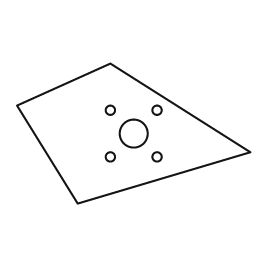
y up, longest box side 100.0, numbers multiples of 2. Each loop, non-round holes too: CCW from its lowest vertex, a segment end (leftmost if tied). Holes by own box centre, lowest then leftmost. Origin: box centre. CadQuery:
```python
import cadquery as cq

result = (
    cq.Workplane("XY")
    .moveTo(-24.0, -30.0)
    .lineTo(50.0, -8.0)
    .lineTo(-10.0, 30.0)
    .lineTo(-50.0, 12.0)
    .close()
    .moveTo(-10.0, -10.0)
    .circle(2.0)
    .moveTo(10.0, -10.0)
    .circle(2.0)
    .moveTo(0.0, 0.0)
    .circle(6.0)
    .moveTo(-10.0, 10.0)
    .circle(2.0)
    .moveTo(10.0, 10.0)
    .circle(2.0)
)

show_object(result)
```